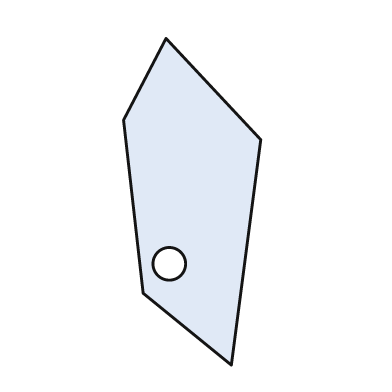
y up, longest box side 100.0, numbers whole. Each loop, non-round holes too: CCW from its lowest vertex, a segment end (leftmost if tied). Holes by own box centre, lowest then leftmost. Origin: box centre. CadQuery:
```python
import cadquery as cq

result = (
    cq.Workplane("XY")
    .moveTo(12.0, -50.0)
    .lineTo(21.0, 19.0)
    .lineTo(-8.0, 50.0)
    .lineTo(-21.0, 25.0)
    .lineTo(-15.0, -28.0)
    .close()
    .moveTo(-7.0, -19.0)
    .circle(5.0)
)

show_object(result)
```